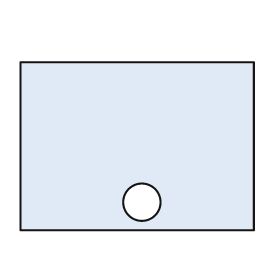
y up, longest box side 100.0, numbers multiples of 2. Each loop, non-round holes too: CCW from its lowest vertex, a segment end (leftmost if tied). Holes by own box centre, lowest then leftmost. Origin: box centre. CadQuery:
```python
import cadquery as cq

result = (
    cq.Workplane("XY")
    .moveTo(-50.0, -36.0)
    .lineTo(50.0, -36.0)
    .lineTo(50.0, 36.0)
    .lineTo(-50.0, 36.0)
    .close()
    .moveTo(2.0, -24.0)
    .circle(8.0)
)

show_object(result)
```